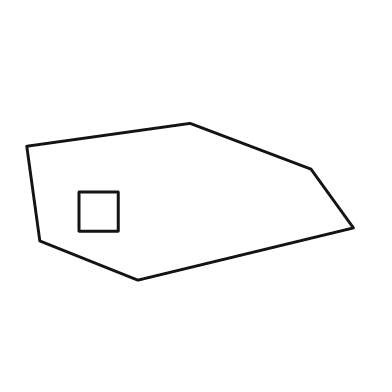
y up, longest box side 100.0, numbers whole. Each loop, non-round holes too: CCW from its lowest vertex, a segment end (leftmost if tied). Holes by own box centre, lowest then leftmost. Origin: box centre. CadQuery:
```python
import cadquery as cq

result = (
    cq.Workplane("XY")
    .moveTo(-16.0, -24.0)
    .lineTo(50.0, -8.0)
    .lineTo(37.0, 10.0)
    .lineTo(0.0, 24.0)
    .lineTo(-50.0, 17.0)
    .lineTo(-46.0, -12.0)
    .close()
    .moveTo(-34.0, -9.0)
    .lineTo(-22.0, -9.0)
    .lineTo(-22.0, 3.0)
    .lineTo(-34.0, 3.0)
    .close()
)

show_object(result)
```